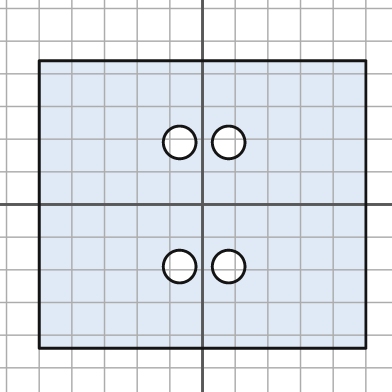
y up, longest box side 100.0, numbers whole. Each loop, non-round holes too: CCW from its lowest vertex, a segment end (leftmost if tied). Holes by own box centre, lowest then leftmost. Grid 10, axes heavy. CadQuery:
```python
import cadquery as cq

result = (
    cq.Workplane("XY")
    .moveTo(-50.0, -44.0)
    .lineTo(50.0, -44.0)
    .lineTo(50.0, 44.0)
    .lineTo(-50.0, 44.0)
    .close()
    .moveTo(-7.0, -19.0)
    .circle(5.0)
    .moveTo(8.0, -19.0)
    .circle(5.0)
    .moveTo(-7.0, 19.0)
    .circle(5.0)
    .moveTo(8.0, 19.0)
    .circle(5.0)
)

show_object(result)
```